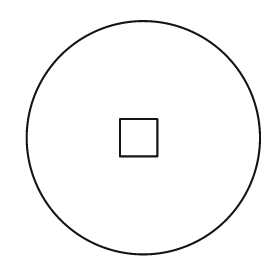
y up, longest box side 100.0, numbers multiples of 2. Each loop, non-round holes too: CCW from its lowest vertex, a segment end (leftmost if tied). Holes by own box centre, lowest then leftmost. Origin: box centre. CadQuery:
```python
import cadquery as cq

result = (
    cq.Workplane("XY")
    .moveTo(0.0, 0.0)
    .circle(50.0)
    .moveTo(-10.0, -8.0)
    .lineTo(6.0, -8.0)
    .lineTo(6.0, 8.0)
    .lineTo(-10.0, 8.0)
    .close()
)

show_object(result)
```